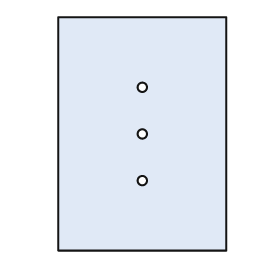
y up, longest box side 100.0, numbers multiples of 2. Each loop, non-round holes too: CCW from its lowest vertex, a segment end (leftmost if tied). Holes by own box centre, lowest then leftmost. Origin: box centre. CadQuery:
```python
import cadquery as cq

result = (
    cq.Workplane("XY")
    .moveTo(-36.0, -50.0)
    .lineTo(36.0, -50.0)
    .lineTo(36.0, 50.0)
    .lineTo(-36.0, 50.0)
    .close()
    .moveTo(0.0, -20.0)
    .circle(2.0)
    .moveTo(0.0, 0.0)
    .circle(2.0)
    .moveTo(0.0, 20.0)
    .circle(2.0)
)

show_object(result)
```